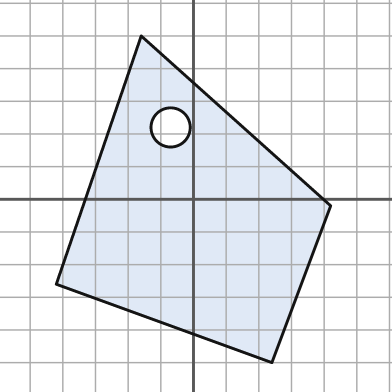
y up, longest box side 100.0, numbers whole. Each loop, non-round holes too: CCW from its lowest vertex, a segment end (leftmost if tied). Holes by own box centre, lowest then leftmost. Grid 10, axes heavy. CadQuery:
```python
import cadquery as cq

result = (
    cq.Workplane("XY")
    .moveTo(24.0, -50.0)
    .lineTo(42.0, -2.0)
    .lineTo(-16.0, 50.0)
    .lineTo(-42.0, -26.0)
    .close()
    .moveTo(-7.0, 22.0)
    .circle(6.0)
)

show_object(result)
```